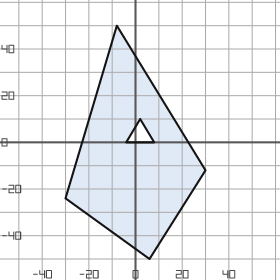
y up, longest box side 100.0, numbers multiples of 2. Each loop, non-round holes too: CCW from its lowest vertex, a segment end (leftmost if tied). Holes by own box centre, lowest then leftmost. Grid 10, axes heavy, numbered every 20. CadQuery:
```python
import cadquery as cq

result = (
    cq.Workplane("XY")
    .moveTo(6.0, -50.0)
    .lineTo(30.0, -12.0)
    .lineTo(-8.0, 50.0)
    .lineTo(-30.0, -24.0)
    .close()
    .moveTo(-4.0, 0.0)
    .lineTo(8.0, 0.0)
    .lineTo(2.0, 10.0)
    .close()
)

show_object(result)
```